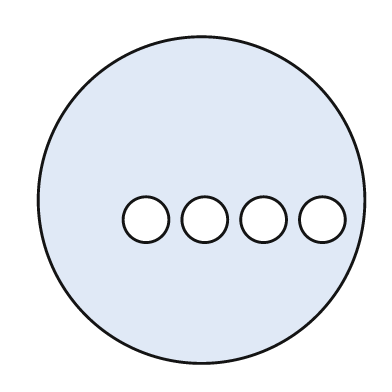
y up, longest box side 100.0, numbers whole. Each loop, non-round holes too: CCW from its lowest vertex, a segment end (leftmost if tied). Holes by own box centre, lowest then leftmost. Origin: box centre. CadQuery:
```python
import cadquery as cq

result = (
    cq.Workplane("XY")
    .moveTo(0.0, 0.0)
    .circle(50.0)
    .moveTo(-17.0, -6.0)
    .circle(7.0)
    .moveTo(1.0, -6.0)
    .circle(7.0)
    .moveTo(19.0, -6.0)
    .circle(7.0)
    .moveTo(37.0, -6.0)
    .circle(7.0)
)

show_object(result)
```